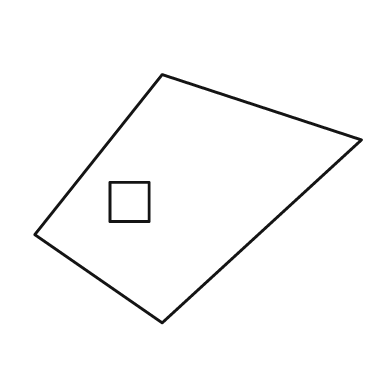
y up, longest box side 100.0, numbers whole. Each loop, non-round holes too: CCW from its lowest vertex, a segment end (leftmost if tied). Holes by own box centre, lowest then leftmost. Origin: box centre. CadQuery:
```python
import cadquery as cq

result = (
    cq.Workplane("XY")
    .moveTo(-11.0, -38.0)
    .lineTo(50.0, 18.0)
    .lineTo(-11.0, 38.0)
    .lineTo(-50.0, -11.0)
    .close()
    .moveTo(-27.0, -7.0)
    .lineTo(-15.0, -7.0)
    .lineTo(-15.0, 5.0)
    .lineTo(-27.0, 5.0)
    .close()
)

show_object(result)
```